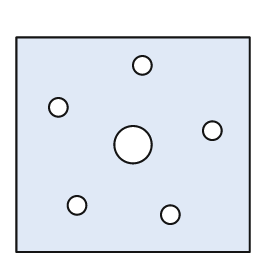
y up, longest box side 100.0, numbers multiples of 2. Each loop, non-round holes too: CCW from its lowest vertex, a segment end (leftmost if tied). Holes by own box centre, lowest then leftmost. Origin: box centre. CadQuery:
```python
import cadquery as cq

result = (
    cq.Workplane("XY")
    .moveTo(-50.0, -46.0)
    .lineTo(50.0, -46.0)
    .lineTo(50.0, 46.0)
    .lineTo(-50.0, 46.0)
    .close()
    .moveTo(16.0, -30.0)
    .circle(4.0)
    .moveTo(-24.0, -26.0)
    .circle(4.0)
    .moveTo(0.0, 0.0)
    .circle(8.0)
    .moveTo(34.0, 6.0)
    .circle(4.0)
    .moveTo(-32.0, 16.0)
    .circle(4.0)
    .moveTo(4.0, 34.0)
    .circle(4.0)
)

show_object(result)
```